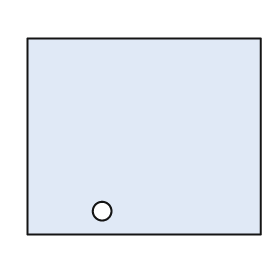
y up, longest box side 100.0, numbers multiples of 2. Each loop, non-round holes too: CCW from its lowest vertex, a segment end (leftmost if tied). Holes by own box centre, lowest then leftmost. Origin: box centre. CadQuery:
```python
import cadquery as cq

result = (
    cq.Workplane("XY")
    .moveTo(-50.0, -42.0)
    .lineTo(50.0, -42.0)
    .lineTo(50.0, 42.0)
    .lineTo(-50.0, 42.0)
    .close()
    .moveTo(-18.0, -32.0)
    .circle(4.0)
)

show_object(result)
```